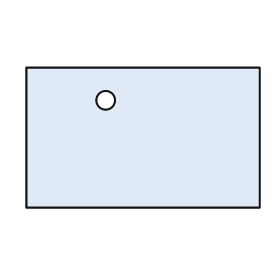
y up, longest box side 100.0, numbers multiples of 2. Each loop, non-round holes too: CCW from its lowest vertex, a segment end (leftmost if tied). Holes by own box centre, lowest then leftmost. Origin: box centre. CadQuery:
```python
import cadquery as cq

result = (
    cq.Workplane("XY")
    .moveTo(-50.0, -30.0)
    .lineTo(50.0, -30.0)
    .lineTo(50.0, 30.0)
    .lineTo(-50.0, 30.0)
    .close()
    .moveTo(-16.0, 16.0)
    .circle(4.0)
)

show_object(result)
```